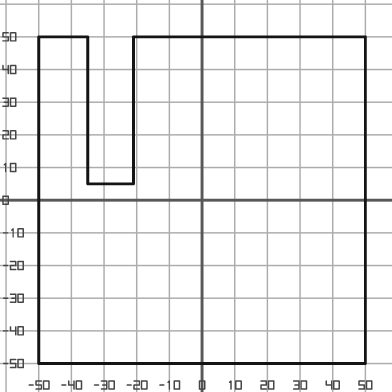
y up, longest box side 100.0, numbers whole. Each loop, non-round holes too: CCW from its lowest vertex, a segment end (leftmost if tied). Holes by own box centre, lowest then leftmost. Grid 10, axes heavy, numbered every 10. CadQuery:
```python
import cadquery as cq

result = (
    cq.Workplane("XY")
    .moveTo(-50.0, -50.0)
    .lineTo(50.0, -50.0)
    .lineTo(50.0, 50.0)
    .lineTo(-21.0, 50.0)
    .lineTo(-21.0, 5.0)
    .lineTo(-35.0, 5.0)
    .lineTo(-35.0, 50.0)
    .lineTo(-50.0, 50.0)
    .close()
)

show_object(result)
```